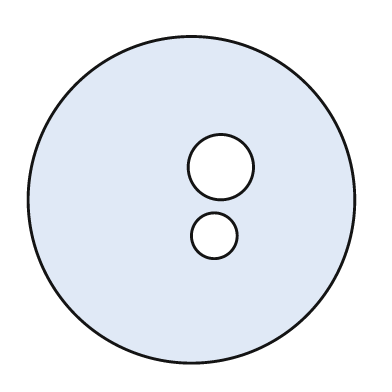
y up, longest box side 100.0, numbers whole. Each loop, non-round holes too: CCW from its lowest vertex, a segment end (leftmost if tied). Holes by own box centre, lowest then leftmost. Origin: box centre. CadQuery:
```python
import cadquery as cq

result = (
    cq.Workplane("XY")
    .moveTo(0.0, 0.0)
    .circle(50.0)
    .moveTo(7.0, -11.0)
    .circle(7.0)
    .moveTo(9.0, 10.0)
    .circle(10.0)
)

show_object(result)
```